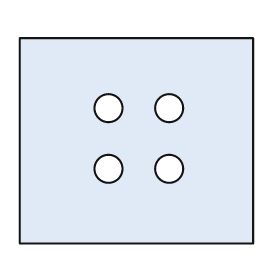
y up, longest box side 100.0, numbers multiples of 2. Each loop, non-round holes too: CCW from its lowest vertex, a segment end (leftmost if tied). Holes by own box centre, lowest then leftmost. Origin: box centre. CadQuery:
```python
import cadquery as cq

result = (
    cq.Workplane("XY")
    .moveTo(-50.0, -44.0)
    .lineTo(50.0, -44.0)
    .lineTo(50.0, 44.0)
    .lineTo(-50.0, 44.0)
    .close()
    .moveTo(-12.0, -12.0)
    .circle(6.0)
    .moveTo(14.0, -12.0)
    .circle(6.0)
    .moveTo(-12.0, 14.0)
    .circle(6.0)
    .moveTo(14.0, 14.0)
    .circle(6.0)
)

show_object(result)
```